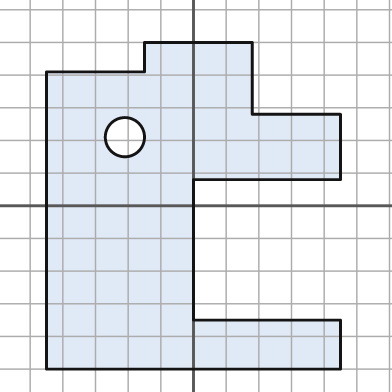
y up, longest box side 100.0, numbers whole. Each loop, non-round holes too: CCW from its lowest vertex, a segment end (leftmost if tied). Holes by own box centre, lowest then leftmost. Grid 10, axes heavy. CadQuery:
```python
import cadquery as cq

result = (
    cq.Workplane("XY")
    .moveTo(-45.0, -50.0)
    .lineTo(45.0, -50.0)
    .lineTo(45.0, -35.0)
    .lineTo(0.0, -35.0)
    .lineTo(0.0, 8.0)
    .lineTo(45.0, 8.0)
    .lineTo(45.0, 28.0)
    .lineTo(18.0, 28.0)
    .lineTo(18.0, 50.0)
    .lineTo(-15.0, 50.0)
    .lineTo(-15.0, 41.0)
    .lineTo(-45.0, 41.0)
    .close()
    .moveTo(-21.0, 21.0)
    .circle(6.0)
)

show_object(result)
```